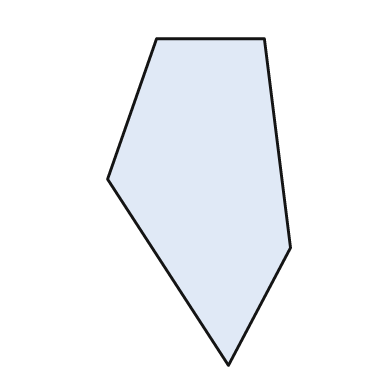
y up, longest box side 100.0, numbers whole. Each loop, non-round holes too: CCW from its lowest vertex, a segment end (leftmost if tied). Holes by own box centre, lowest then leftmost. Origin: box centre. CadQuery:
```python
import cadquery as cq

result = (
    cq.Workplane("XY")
    .moveTo(9.0, -50.0)
    .lineTo(28.0, -14.0)
    .lineTo(20.0, 50.0)
    .lineTo(-13.0, 50.0)
    .lineTo(-28.0, 7.0)
    .close()
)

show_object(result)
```